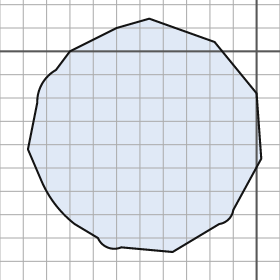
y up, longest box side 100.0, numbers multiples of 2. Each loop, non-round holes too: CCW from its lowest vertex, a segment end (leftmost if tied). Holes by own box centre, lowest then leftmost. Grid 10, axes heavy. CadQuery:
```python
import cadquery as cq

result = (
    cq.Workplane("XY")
    .moveTo(-36.0, -86.0)
    .lineTo(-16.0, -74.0)
    .threePointArc((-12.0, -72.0), (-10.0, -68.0))
    .lineTo(2.0, -46.0)
    .lineTo(0.0, -18.0)
    .lineTo(-18.0, 4.0)
    .lineTo(-46.0, 14.0)
    .lineTo(-60.0, 10.0)
    .lineTo(-80.0, 0.0)
    .lineTo(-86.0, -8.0)
    .threePointArc((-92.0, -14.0), (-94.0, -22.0))
    .lineTo(-98.0, -42.0)
    .lineTo(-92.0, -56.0)
    .threePointArc((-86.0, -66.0), (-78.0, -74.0))
    .lineTo(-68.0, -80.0)
    .threePointArc((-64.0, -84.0), (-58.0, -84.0))
    .close()
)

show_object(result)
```